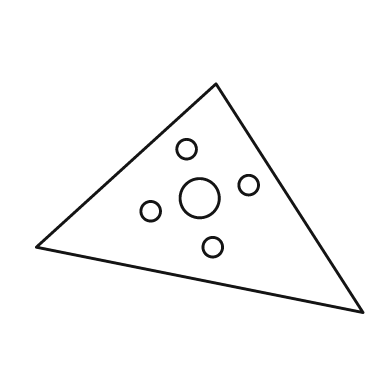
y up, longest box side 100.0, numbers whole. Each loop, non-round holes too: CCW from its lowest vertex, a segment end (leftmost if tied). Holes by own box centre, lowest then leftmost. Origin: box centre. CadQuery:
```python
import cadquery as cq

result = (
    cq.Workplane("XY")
    .moveTo(50.0, -35.0)
    .lineTo(5.0, 35.0)
    .lineTo(-50.0, -15.0)
    .close()
    .moveTo(4.0, -15.0)
    .circle(3.0)
    .moveTo(-15.0, -4.0)
    .circle(3.0)
    .moveTo(0.0, 0.0)
    .circle(6.0)
    .moveTo(15.0, 4.0)
    .circle(3.0)
    .moveTo(-4.0, 15.0)
    .circle(3.0)
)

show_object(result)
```